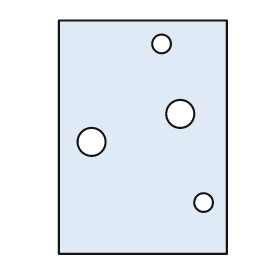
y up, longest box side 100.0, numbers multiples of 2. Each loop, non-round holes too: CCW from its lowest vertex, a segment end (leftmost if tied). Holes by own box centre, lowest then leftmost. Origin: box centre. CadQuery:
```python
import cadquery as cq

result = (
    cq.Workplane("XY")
    .moveTo(-36.0, -50.0)
    .lineTo(36.0, -50.0)
    .lineTo(36.0, 50.0)
    .lineTo(-36.0, 50.0)
    .close()
    .moveTo(26.0, -28.0)
    .circle(4.0)
    .moveTo(-22.0, -2.0)
    .circle(6.0)
    .moveTo(16.0, 10.0)
    .circle(6.0)
    .moveTo(8.0, 40.0)
    .circle(4.0)
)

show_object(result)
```